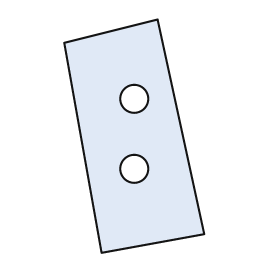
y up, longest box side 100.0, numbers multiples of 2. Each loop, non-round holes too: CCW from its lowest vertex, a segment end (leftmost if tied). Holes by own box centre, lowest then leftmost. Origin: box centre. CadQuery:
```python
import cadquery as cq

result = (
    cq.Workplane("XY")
    .moveTo(-14.0, -50.0)
    .lineTo(30.0, -42.0)
    .lineTo(10.0, 50.0)
    .lineTo(-30.0, 40.0)
    .close()
    .moveTo(0.0, -14.0)
    .circle(6.0)
    .moveTo(0.0, 16.0)
    .circle(6.0)
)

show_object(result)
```